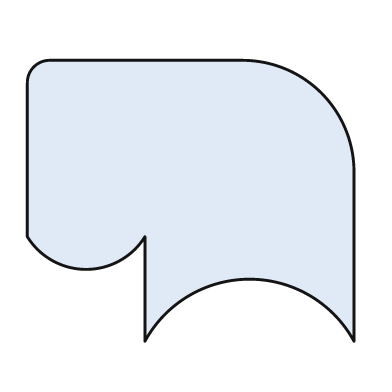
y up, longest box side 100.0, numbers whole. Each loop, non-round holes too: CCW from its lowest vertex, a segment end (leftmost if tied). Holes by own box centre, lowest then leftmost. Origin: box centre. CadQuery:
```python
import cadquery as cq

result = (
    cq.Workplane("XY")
    .moveTo(-14.0, -43.0)
    .threePointArc((18.0, -24.0), (50.0, -43.0))
    .lineTo(50.0, 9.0)
    .threePointArc((40.0, 33.0), (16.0, 43.0))
    .lineTo(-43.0, 43.0)
    .threePointArc((-48.0, 41.0), (-50.0, 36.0))
    .lineTo(-50.0, -11.0)
    .threePointArc((-32.0, -21.0), (-14.0, -11.0))
    .close()
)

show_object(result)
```